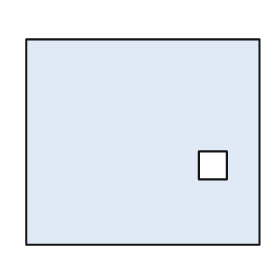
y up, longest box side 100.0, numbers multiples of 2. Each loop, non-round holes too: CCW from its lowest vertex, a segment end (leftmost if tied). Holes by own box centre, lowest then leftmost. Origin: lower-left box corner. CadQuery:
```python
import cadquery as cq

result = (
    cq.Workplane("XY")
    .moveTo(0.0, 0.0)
    .lineTo(100.0, 0.0)
    .lineTo(100.0, 88.0)
    .lineTo(0.0, 88.0)
    .close()
    .moveTo(74.0, 28.0)
    .lineTo(86.0, 28.0)
    .lineTo(86.0, 40.0)
    .lineTo(74.0, 40.0)
    .close()
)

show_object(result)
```